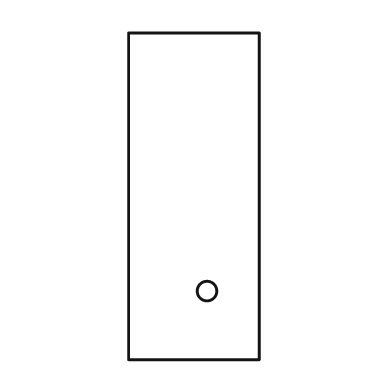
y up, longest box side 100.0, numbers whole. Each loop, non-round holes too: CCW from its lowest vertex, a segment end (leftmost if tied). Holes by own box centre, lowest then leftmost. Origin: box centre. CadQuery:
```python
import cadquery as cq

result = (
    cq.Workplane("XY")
    .moveTo(-20.0, -50.0)
    .lineTo(20.0, -50.0)
    .lineTo(20.0, 50.0)
    .lineTo(-20.0, 50.0)
    .close()
    .moveTo(4.0, -29.0)
    .circle(3.0)
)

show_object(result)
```